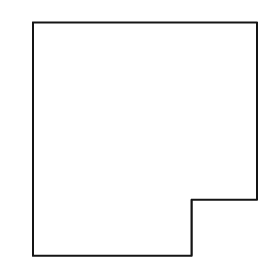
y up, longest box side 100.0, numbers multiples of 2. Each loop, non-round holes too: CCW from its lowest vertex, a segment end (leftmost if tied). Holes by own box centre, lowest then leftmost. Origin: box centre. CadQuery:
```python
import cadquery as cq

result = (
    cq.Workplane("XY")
    .moveTo(-48.0, -50.0)
    .lineTo(20.0, -50.0)
    .lineTo(20.0, -26.0)
    .lineTo(48.0, -26.0)
    .lineTo(48.0, 50.0)
    .lineTo(-48.0, 50.0)
    .close()
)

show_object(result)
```